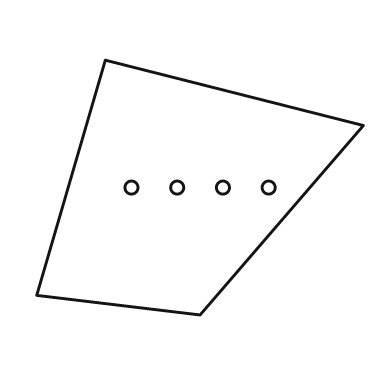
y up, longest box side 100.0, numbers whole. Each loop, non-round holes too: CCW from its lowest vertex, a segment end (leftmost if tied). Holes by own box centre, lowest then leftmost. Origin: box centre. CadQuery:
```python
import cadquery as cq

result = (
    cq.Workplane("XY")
    .moveTo(0.0, -39.0)
    .lineTo(50.0, 19.0)
    .lineTo(-29.0, 39.0)
    .lineTo(-50.0, -33.0)
    .close()
    .moveTo(-21.0, 0.0)
    .circle(2.0)
    .moveTo(-7.0, 0.0)
    .circle(2.0)
    .moveTo(7.0, 0.0)
    .circle(2.0)
    .moveTo(21.0, 0.0)
    .circle(2.0)
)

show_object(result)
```